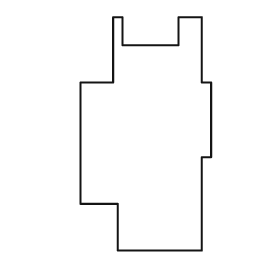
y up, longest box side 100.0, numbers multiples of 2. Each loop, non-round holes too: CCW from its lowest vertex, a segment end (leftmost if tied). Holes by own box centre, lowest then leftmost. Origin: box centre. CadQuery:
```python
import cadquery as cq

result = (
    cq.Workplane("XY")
    .moveTo(-12.0, -50.0)
    .lineTo(24.0, -50.0)
    .lineTo(24.0, -10.0)
    .lineTo(28.0, -10.0)
    .lineTo(28.0, 22.0)
    .lineTo(24.0, 22.0)
    .lineTo(24.0, 50.0)
    .lineTo(14.0, 50.0)
    .lineTo(14.0, 38.0)
    .lineTo(-10.0, 38.0)
    .lineTo(-10.0, 50.0)
    .lineTo(-14.0, 50.0)
    .lineTo(-14.0, 22.0)
    .lineTo(-28.0, 22.0)
    .lineTo(-28.0, -30.0)
    .lineTo(-12.0, -30.0)
    .close()
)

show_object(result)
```